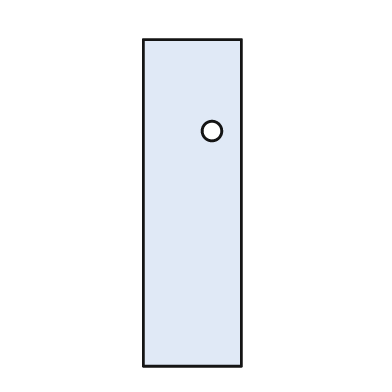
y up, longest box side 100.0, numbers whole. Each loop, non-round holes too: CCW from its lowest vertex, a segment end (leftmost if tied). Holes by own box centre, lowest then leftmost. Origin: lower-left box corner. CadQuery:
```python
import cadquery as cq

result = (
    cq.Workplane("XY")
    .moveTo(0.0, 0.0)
    .lineTo(30.0, 0.0)
    .lineTo(30.0, 100.0)
    .lineTo(0.0, 100.0)
    .close()
    .moveTo(21.0, 72.0)
    .circle(3.0)
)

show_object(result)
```